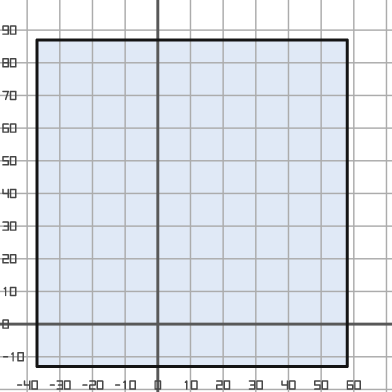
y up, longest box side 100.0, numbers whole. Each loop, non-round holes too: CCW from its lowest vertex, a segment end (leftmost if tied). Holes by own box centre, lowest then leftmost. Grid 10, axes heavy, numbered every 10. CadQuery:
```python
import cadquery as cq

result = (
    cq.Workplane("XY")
    .moveTo(-37.0, -13.0)
    .lineTo(58.0, -13.0)
    .lineTo(58.0, 87.0)
    .lineTo(-37.0, 87.0)
    .close()
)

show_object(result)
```